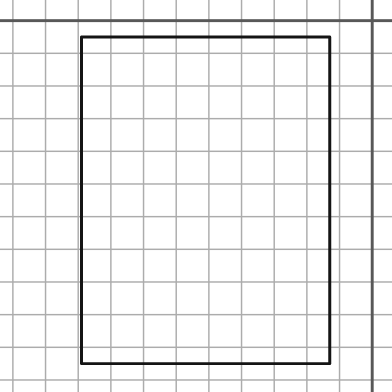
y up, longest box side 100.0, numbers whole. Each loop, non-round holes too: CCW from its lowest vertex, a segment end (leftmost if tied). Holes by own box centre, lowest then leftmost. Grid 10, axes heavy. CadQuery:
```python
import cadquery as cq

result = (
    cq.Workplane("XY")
    .moveTo(-89.0, -105.0)
    .lineTo(-13.0, -105.0)
    .lineTo(-13.0, -5.0)
    .lineTo(-89.0, -5.0)
    .close()
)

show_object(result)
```